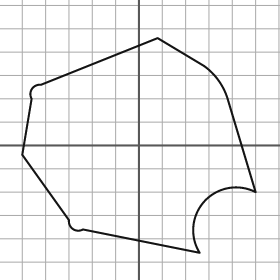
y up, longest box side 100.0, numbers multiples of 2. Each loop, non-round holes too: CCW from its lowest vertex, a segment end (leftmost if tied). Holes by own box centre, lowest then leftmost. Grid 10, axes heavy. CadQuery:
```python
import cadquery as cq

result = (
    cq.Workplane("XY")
    .moveTo(26.0, -46.0)
    .threePointArc((28.0, -24.0), (50.0, -20.0))
    .lineTo(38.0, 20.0)
    .threePointArc((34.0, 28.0), (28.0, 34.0))
    .lineTo(8.0, 46.0)
    .lineTo(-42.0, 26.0)
    .threePointArc((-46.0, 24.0), (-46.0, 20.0))
    .lineTo(-50.0, -4.0)
    .lineTo(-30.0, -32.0)
    .threePointArc((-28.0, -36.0), (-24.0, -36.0))
    .close()
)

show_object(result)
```